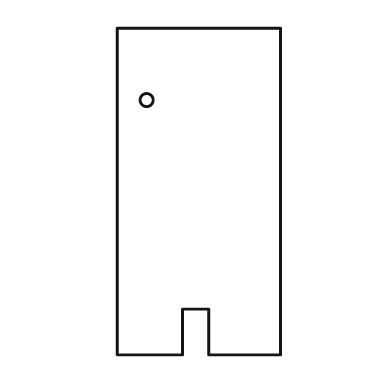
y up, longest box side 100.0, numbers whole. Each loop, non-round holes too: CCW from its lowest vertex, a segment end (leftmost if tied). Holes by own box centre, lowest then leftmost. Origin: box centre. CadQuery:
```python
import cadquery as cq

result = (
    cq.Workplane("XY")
    .moveTo(-25.0, -50.0)
    .lineTo(-5.0, -50.0)
    .lineTo(-5.0, -36.0)
    .lineTo(3.0, -36.0)
    .lineTo(3.0, -50.0)
    .lineTo(25.0, -50.0)
    .lineTo(25.0, 50.0)
    .lineTo(-25.0, 50.0)
    .close()
    .moveTo(-16.0, 28.0)
    .circle(2.0)
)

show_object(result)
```